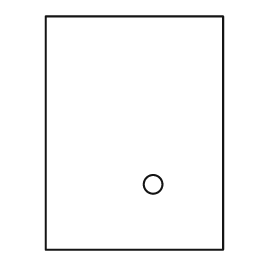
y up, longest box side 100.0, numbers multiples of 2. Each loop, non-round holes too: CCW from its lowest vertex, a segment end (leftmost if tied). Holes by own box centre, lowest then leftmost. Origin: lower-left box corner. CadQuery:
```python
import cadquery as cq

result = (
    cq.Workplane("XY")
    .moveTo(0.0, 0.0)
    .lineTo(76.0, 0.0)
    .lineTo(76.0, 100.0)
    .lineTo(0.0, 100.0)
    .close()
    .moveTo(46.0, 28.0)
    .circle(4.0)
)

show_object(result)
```